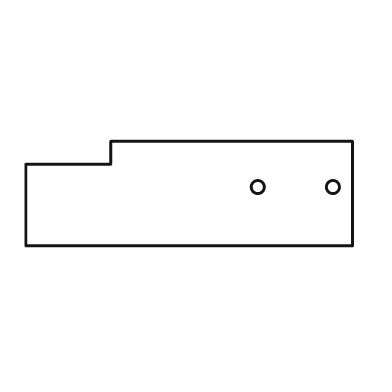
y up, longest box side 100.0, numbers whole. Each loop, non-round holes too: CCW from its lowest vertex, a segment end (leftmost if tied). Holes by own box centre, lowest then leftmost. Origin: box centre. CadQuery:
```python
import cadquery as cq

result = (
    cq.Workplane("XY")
    .moveTo(-50.0, -16.0)
    .lineTo(50.0, -16.0)
    .lineTo(50.0, 16.0)
    .lineTo(-24.0, 16.0)
    .lineTo(-24.0, 9.0)
    .lineTo(-50.0, 9.0)
    .close()
    .moveTo(21.0, 2.0)
    .circle(2.0)
    .moveTo(44.0, 2.0)
    .circle(2.0)
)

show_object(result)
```